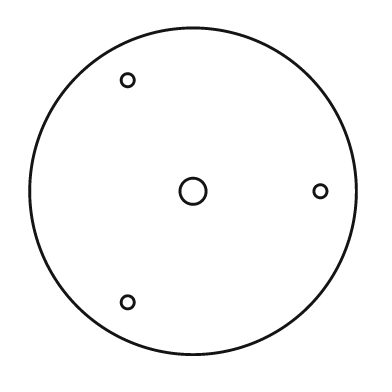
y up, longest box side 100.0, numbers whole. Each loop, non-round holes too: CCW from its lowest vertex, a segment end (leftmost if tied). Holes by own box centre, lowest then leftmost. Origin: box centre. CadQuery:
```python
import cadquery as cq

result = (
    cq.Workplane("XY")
    .moveTo(0.0, 0.0)
    .circle(50.0)
    .moveTo(-20.0, -34.0)
    .circle(2.0)
    .moveTo(0.0, 0.0)
    .circle(4.0)
    .moveTo(39.0, 0.0)
    .circle(2.0)
    .moveTo(-20.0, 34.0)
    .circle(2.0)
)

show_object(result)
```